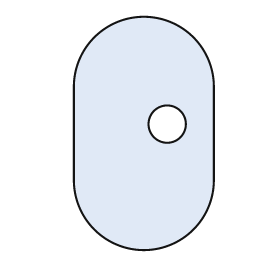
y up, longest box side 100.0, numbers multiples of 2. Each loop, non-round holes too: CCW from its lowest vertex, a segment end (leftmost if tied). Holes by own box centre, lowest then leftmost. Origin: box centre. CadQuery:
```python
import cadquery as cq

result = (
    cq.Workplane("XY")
    .moveTo(-30.0, -20.0)
    .threePointArc((0.0, -50.0), (30.0, -20.0))
    .lineTo(30.0, 20.0)
    .threePointArc((0.0, 50.0), (-30.0, 20.0))
    .close()
    .moveTo(10.0, 4.0)
    .circle(8.0)
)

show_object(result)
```